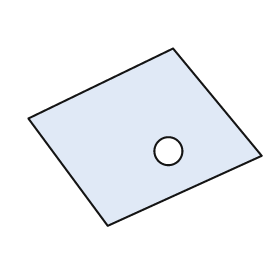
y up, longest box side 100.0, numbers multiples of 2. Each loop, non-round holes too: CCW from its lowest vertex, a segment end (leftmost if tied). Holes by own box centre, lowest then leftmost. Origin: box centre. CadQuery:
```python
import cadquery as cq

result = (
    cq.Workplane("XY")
    .moveTo(-16.0, -38.0)
    .lineTo(50.0, -8.0)
    .lineTo(12.0, 38.0)
    .lineTo(-50.0, 8.0)
    .close()
    .moveTo(10.0, -6.0)
    .circle(6.0)
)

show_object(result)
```